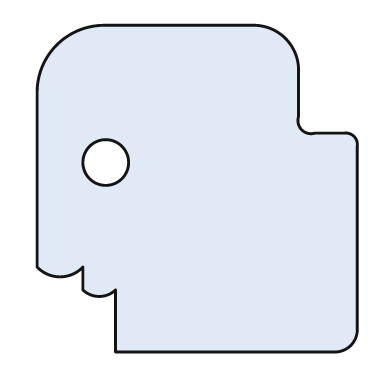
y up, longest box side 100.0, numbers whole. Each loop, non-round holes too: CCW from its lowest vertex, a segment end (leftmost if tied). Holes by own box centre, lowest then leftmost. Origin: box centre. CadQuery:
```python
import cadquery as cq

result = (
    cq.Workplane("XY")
    .moveTo(-25.0, -50.0)
    .lineTo(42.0, -50.0)
    .threePointArc((47.0, -48.0), (49.0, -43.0))
    .lineTo(49.0, 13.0)
    .threePointArc((48.0, 16.0), (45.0, 17.0))
    .lineTo(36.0, 17.0)
    .threePointArc((32.0, 18.0), (31.0, 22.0))
    .lineTo(31.0, 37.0)
    .threePointArc((27.0, 46.0), (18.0, 50.0))
    .lineTo(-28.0, 50.0)
    .threePointArc((-43.0, 44.0), (-49.0, 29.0))
    .lineTo(-49.0, -24.0)
    .threePointArc((-42.0, -27.0), (-35.0, -24.0))
    .lineTo(-35.0, -31.0)
    .threePointArc((-30.0, -33.0), (-25.0, -31.0))
    .close()
    .moveTo(-28.0, 8.0)
    .circle(7.0)
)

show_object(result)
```